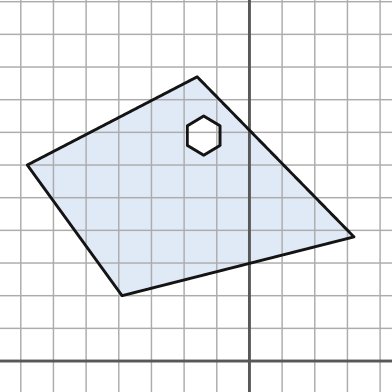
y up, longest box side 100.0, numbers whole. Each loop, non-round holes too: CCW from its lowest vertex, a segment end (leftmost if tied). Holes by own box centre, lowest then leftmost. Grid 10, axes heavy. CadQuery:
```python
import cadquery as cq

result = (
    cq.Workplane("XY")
    .moveTo(-39.0, 20.0)
    .lineTo(32.0, 38.0)
    .lineTo(-16.0, 87.0)
    .lineTo(-68.0, 60.0)
    .close()
    .moveTo(-14.0, 63.0)
    .lineTo(-9.0, 66.0)
    .lineTo(-9.0, 72.0)
    .lineTo(-14.0, 75.0)
    .lineTo(-19.0, 72.0)
    .lineTo(-19.0, 66.0)
    .close()
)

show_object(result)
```